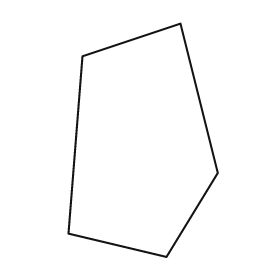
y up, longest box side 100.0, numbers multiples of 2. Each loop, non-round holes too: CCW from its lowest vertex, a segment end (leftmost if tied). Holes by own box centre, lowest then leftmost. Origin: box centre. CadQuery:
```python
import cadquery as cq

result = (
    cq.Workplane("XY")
    .moveTo(10.0, -50.0)
    .lineTo(32.0, -14.0)
    .lineTo(16.0, 50.0)
    .lineTo(-26.0, 36.0)
    .lineTo(-32.0, -40.0)
    .close()
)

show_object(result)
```